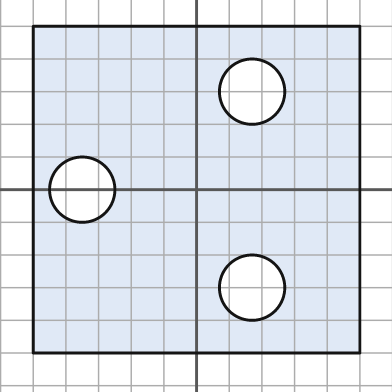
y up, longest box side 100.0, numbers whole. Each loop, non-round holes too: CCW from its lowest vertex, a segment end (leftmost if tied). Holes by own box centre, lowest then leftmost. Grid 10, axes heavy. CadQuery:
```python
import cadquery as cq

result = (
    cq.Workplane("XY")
    .moveTo(-50.0, -50.0)
    .lineTo(50.0, -50.0)
    .lineTo(50.0, 50.0)
    .lineTo(-50.0, 50.0)
    .close()
    .moveTo(17.0, -30.0)
    .circle(10.0)
    .moveTo(-35.0, 0.0)
    .circle(10.0)
    .moveTo(17.0, 30.0)
    .circle(10.0)
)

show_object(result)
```